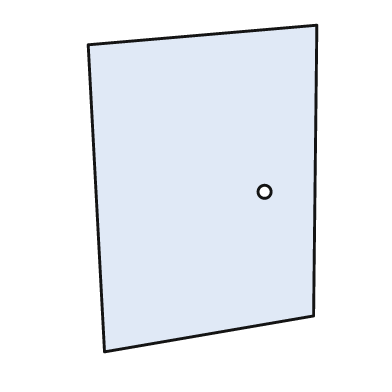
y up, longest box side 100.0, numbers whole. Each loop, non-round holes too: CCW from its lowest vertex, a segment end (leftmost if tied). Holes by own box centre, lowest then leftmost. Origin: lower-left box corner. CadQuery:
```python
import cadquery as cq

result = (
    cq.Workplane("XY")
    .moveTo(5.0, 0.0)
    .lineTo(69.0, 11.0)
    .lineTo(70.0, 100.0)
    .lineTo(0.0, 94.0)
    .close()
    .moveTo(54.0, 49.0)
    .circle(2.0)
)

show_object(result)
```